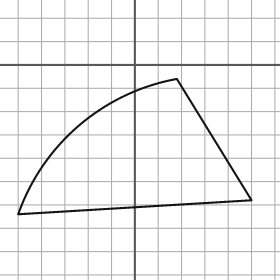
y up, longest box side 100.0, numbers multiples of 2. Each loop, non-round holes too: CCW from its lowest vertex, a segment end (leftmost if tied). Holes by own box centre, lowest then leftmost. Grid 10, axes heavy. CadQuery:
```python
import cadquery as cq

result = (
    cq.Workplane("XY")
    .moveTo(-50.0, -64.0)
    .lineTo(50.0, -58.0)
    .lineTo(18.0, -6.0)
    .threePointArc((-24.0, -26.0), (-50.0, -64.0))
    .close()
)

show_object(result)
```